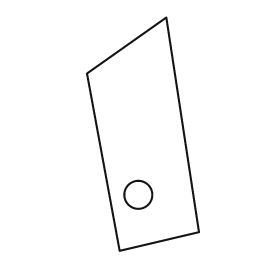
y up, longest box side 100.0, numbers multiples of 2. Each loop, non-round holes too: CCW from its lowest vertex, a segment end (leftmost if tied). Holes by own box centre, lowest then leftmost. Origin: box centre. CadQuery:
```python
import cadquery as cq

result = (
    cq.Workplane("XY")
    .moveTo(-10.0, -50.0)
    .lineTo(24.0, -42.0)
    .lineTo(10.0, 50.0)
    .lineTo(-24.0, 26.0)
    .close()
    .moveTo(-2.0, -26.0)
    .circle(6.0)
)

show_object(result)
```